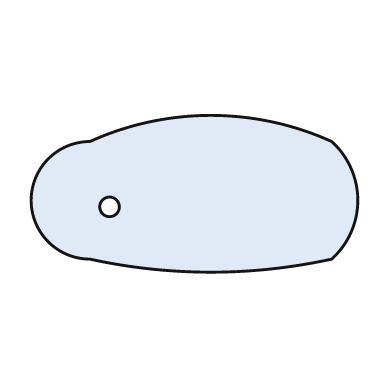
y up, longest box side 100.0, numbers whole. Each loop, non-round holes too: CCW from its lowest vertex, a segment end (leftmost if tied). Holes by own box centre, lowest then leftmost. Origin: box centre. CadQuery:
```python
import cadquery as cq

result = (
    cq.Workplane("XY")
    .moveTo(-32.0, -20.0)
    .threePointArc((5.0, -24.0), (42.0, -20.0))
    .threePointArc((50.0, -2.0), (42.0, 16.0))
    .threePointArc((5.0, 24.0), (-32.0, 16.0))
    .threePointArc((-50.0, -2.0), (-32.0, -20.0))
    .close()
    .moveTo(-26.0, -4.0)
    .circle(3.0)
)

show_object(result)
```